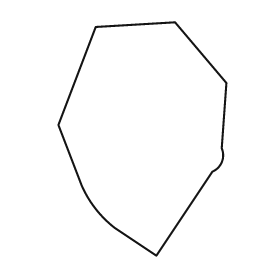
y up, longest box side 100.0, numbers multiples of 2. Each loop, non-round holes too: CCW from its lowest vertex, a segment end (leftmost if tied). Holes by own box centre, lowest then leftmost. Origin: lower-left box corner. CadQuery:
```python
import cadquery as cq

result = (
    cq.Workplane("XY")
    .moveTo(42.0, 0.0)
    .lineTo(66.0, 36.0)
    .threePointArc((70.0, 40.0), (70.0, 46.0))
    .lineTo(72.0, 74.0)
    .lineTo(50.0, 100.0)
    .lineTo(16.0, 98.0)
    .lineTo(0.0, 56.0)
    .lineTo(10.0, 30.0)
    .threePointArc((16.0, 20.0), (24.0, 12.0))
    .close()
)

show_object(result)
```